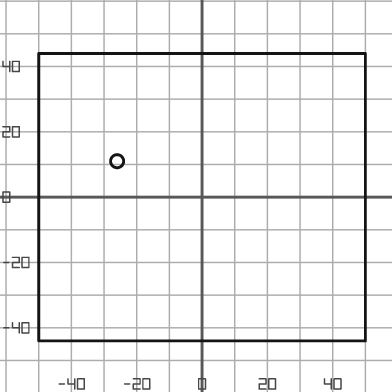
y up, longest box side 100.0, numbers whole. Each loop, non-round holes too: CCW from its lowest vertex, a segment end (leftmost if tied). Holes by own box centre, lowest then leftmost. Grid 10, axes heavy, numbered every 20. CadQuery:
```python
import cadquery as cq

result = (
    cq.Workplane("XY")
    .moveTo(-50.0, -44.0)
    .lineTo(50.0, -44.0)
    .lineTo(50.0, 44.0)
    .lineTo(-50.0, 44.0)
    .close()
    .moveTo(-26.0, 11.0)
    .circle(2.0)
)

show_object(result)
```